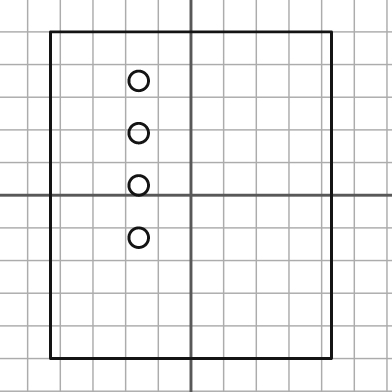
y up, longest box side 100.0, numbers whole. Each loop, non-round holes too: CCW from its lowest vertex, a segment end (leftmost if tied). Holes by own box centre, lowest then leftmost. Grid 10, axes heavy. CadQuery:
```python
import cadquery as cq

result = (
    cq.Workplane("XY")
    .moveTo(-43.0, -50.0)
    .lineTo(43.0, -50.0)
    .lineTo(43.0, 50.0)
    .lineTo(-43.0, 50.0)
    .close()
    .moveTo(-16.0, -13.0)
    .circle(3.0)
    .moveTo(-16.0, 3.0)
    .circle(3.0)
    .moveTo(-16.0, 19.0)
    .circle(3.0)
    .moveTo(-16.0, 35.0)
    .circle(3.0)
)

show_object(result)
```